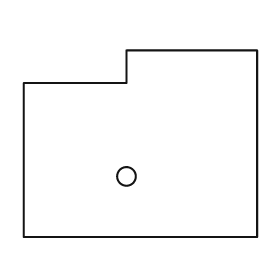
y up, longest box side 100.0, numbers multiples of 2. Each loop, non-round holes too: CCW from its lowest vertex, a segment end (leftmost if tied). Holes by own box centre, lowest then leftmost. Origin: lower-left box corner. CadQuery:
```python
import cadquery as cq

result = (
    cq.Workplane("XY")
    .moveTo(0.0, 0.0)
    .lineTo(100.0, 0.0)
    .lineTo(100.0, 80.0)
    .lineTo(44.0, 80.0)
    .lineTo(44.0, 66.0)
    .lineTo(0.0, 66.0)
    .close()
    .moveTo(44.0, 26.0)
    .circle(4.0)
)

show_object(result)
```